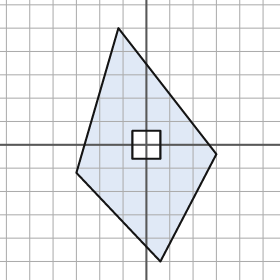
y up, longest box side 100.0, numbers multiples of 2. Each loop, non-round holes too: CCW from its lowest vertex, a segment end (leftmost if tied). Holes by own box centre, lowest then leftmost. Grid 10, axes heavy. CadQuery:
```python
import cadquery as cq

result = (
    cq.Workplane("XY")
    .moveTo(6.0, -50.0)
    .lineTo(30.0, -4.0)
    .lineTo(-12.0, 50.0)
    .lineTo(-30.0, -12.0)
    .close()
    .moveTo(-6.0, -6.0)
    .lineTo(6.0, -6.0)
    .lineTo(6.0, 6.0)
    .lineTo(-6.0, 6.0)
    .close()
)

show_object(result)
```